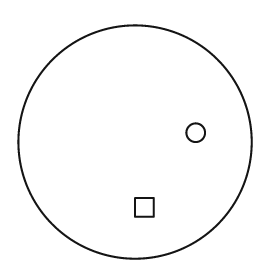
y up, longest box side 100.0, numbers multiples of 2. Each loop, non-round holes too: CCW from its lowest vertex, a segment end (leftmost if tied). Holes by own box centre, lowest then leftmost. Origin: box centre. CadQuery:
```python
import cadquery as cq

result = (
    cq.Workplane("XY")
    .moveTo(0.0, 0.0)
    .circle(50.0)
    .moveTo(0.0, -32.0)
    .lineTo(8.0, -32.0)
    .lineTo(8.0, -24.0)
    .lineTo(0.0, -24.0)
    .close()
    .moveTo(26.0, 4.0)
    .circle(4.0)
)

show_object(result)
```